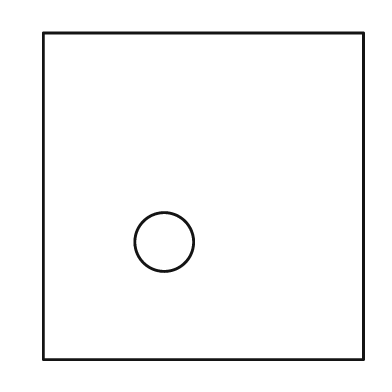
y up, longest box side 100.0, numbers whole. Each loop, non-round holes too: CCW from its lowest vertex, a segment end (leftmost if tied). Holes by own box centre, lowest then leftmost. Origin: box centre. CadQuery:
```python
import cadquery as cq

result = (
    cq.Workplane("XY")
    .moveTo(-49.0, -50.0)
    .lineTo(49.0, -50.0)
    .lineTo(49.0, 50.0)
    .lineTo(-49.0, 50.0)
    .close()
    .moveTo(-12.0, -14.0)
    .circle(9.0)
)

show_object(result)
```